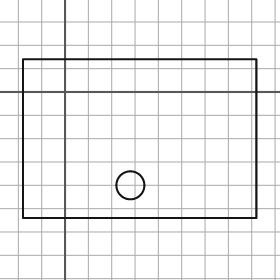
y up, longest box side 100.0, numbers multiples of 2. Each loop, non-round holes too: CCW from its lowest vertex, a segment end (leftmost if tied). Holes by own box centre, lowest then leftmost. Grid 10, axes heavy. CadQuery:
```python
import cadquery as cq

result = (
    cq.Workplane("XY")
    .moveTo(-18.0, -54.0)
    .lineTo(82.0, -54.0)
    .lineTo(82.0, 14.0)
    .lineTo(-18.0, 14.0)
    .close()
    .moveTo(28.0, -40.0)
    .circle(6.0)
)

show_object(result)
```